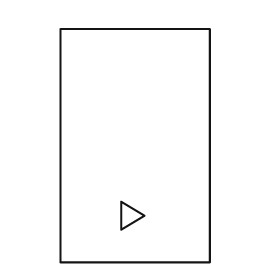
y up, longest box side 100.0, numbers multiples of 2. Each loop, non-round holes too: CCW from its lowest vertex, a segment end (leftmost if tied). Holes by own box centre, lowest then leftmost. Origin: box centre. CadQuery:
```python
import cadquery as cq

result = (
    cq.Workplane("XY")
    .moveTo(-32.0, -50.0)
    .lineTo(32.0, -50.0)
    .lineTo(32.0, 50.0)
    .lineTo(-32.0, 50.0)
    .close()
    .moveTo(-6.0, -36.0)
    .lineTo(4.0, -30.0)
    .lineTo(-6.0, -24.0)
    .close()
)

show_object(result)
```